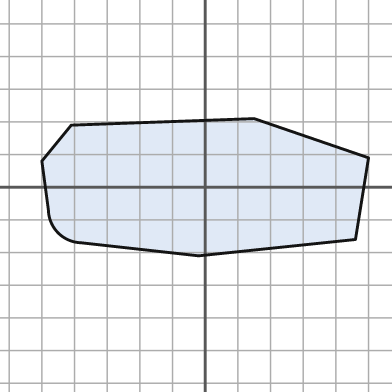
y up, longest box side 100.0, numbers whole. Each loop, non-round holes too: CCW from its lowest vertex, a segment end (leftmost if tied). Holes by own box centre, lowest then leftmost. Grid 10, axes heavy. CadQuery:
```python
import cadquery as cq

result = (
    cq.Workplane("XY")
    .moveTo(-2.0, -21.0)
    .lineTo(46.0, -16.0)
    .lineTo(50.0, 9.0)
    .lineTo(15.0, 21.0)
    .lineTo(-41.0, 19.0)
    .lineTo(-50.0, 8.0)
    .lineTo(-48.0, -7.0)
    .threePointArc((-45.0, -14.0), (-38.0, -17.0))
    .close()
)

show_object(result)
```